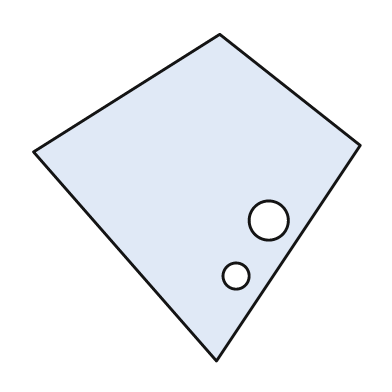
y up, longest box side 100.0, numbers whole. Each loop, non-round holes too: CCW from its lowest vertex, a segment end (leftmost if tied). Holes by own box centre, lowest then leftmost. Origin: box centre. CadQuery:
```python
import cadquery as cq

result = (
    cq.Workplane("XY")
    .moveTo(6.0, -50.0)
    .lineTo(50.0, 16.0)
    .lineTo(7.0, 50.0)
    .lineTo(-50.0, 14.0)
    .close()
    .moveTo(12.0, -24.0)
    .circle(4.0)
    .moveTo(22.0, -7.0)
    .circle(6.0)
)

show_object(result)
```